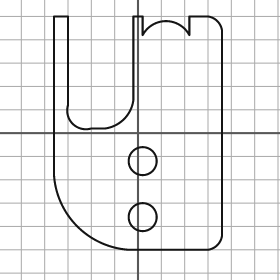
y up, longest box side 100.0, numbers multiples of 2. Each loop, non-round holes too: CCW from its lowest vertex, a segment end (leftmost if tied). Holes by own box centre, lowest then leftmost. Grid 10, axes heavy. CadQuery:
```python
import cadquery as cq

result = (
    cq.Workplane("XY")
    .moveTo(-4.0, -50.0)
    .lineTo(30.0, -50.0)
    .threePointArc((34.0, -48.0), (36.0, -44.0))
    .lineTo(36.0, 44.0)
    .threePointArc((34.0, 48.0), (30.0, 50.0))
    .lineTo(22.0, 50.0)
    .lineTo(22.0, 42.0)
    .threePointArc((12.0, 48.0), (2.0, 42.0))
    .lineTo(2.0, 50.0)
    .lineTo(-2.0, 50.0)
    .lineTo(-2.0, 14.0)
    .threePointArc((-6.0, 6.0), (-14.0, 2.0))
    .lineTo(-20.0, 2.0)
    .threePointArc((-28.0, 4.0), (-30.0, 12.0))
    .lineTo(-30.0, 50.0)
    .lineTo(-36.0, 50.0)
    .lineTo(-36.0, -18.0)
    .threePointArc((-26.0, -40.0), (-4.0, -50.0))
    .close()
    .moveTo(2.0, -36.0)
    .circle(6.0)
    .moveTo(2.0, -12.0)
    .circle(6.0)
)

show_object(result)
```